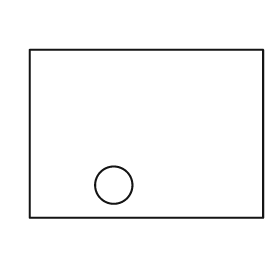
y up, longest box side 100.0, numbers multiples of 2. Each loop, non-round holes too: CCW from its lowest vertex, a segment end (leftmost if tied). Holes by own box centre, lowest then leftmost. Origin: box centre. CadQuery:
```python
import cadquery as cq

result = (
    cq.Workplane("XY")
    .moveTo(-50.0, -36.0)
    .lineTo(50.0, -36.0)
    .lineTo(50.0, 36.0)
    .lineTo(-50.0, 36.0)
    .close()
    .moveTo(-14.0, -22.0)
    .circle(8.0)
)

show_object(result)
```